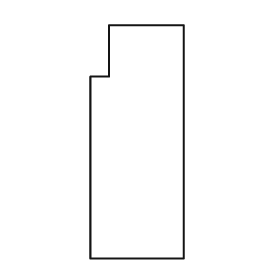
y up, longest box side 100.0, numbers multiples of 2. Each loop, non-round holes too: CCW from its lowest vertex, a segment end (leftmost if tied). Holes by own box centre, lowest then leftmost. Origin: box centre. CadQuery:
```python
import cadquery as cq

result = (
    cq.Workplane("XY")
    .moveTo(-20.0, -50.0)
    .lineTo(20.0, -50.0)
    .lineTo(20.0, 50.0)
    .lineTo(-12.0, 50.0)
    .lineTo(-12.0, 28.0)
    .lineTo(-20.0, 28.0)
    .close()
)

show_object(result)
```